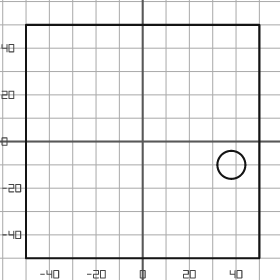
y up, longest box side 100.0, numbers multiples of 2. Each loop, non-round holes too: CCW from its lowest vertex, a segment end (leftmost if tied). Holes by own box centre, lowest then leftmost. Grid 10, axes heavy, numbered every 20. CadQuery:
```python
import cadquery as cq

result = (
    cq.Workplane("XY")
    .moveTo(-50.0, -50.0)
    .lineTo(50.0, -50.0)
    .lineTo(50.0, 50.0)
    .lineTo(-50.0, 50.0)
    .close()
    .moveTo(38.0, -10.0)
    .circle(6.0)
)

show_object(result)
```